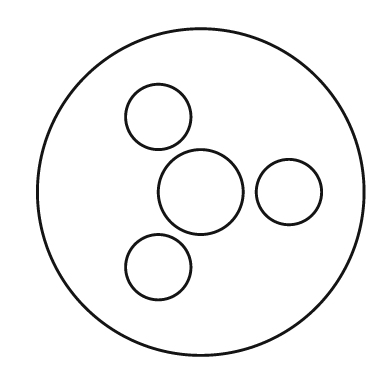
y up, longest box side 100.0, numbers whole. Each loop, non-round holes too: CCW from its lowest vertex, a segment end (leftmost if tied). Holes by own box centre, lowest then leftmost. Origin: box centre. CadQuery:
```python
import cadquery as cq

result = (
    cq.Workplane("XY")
    .moveTo(0.0, 0.0)
    .circle(50.0)
    .moveTo(-13.0, -23.0)
    .circle(10.0)
    .moveTo(0.0, 0.0)
    .circle(13.0)
    .moveTo(27.0, 0.0)
    .circle(10.0)
    .moveTo(-13.0, 23.0)
    .circle(10.0)
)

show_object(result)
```